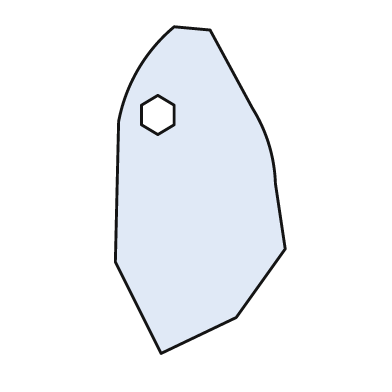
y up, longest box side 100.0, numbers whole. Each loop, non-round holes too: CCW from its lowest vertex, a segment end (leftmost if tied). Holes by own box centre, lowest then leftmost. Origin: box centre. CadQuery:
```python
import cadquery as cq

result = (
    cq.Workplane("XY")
    .moveTo(-12.0, -50.0)
    .lineTo(11.0, -39.0)
    .lineTo(26.0, -18.0)
    .lineTo(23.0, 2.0)
    .threePointArc((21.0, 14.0), (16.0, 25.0))
    .lineTo(3.0, 49.0)
    .lineTo(-8.0, 50.0)
    .threePointArc((-19.0, 37.0), (-25.0, 21.0))
    .lineTo(-26.0, -22.0)
    .close()
    .moveTo(-13.0, 17.0)
    .lineTo(-8.0, 20.0)
    .lineTo(-8.0, 26.0)
    .lineTo(-13.0, 29.0)
    .lineTo(-18.0, 26.0)
    .lineTo(-18.0, 20.0)
    .close()
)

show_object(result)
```